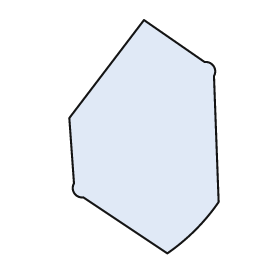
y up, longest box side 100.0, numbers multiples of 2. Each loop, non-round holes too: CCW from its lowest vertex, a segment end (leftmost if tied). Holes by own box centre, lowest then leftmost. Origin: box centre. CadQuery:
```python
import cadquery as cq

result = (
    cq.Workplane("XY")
    .moveTo(10.0, -50.0)
    .threePointArc((22.0, -40.0), (32.0, -28.0))
    .lineTo(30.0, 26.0)
    .threePointArc((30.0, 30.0), (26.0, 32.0))
    .lineTo(0.0, 50.0)
    .lineTo(-32.0, 8.0)
    .lineTo(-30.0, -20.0)
    .threePointArc((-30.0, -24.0), (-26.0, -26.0))
    .close()
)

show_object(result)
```